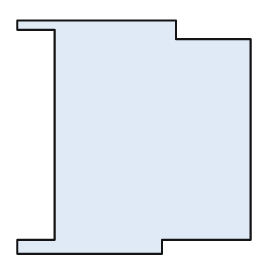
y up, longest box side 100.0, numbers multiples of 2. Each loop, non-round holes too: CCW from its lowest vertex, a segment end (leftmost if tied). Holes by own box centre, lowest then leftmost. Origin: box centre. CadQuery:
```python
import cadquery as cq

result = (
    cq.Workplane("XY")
    .moveTo(-50.0, -50.0)
    .lineTo(12.0, -50.0)
    .lineTo(12.0, -44.0)
    .lineTo(50.0, -44.0)
    .lineTo(50.0, 42.0)
    .lineTo(18.0, 42.0)
    .lineTo(18.0, 50.0)
    .lineTo(-50.0, 50.0)
    .lineTo(-50.0, 46.0)
    .lineTo(-34.0, 46.0)
    .lineTo(-34.0, -44.0)
    .lineTo(-50.0, -44.0)
    .close()
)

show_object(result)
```